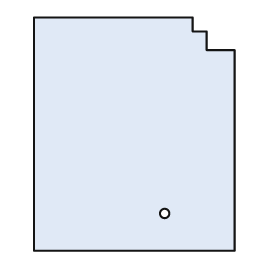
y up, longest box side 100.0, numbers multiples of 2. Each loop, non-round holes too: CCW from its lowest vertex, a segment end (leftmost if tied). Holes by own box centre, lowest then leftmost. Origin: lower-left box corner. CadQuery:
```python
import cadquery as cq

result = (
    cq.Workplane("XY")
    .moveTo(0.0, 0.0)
    .lineTo(86.0, 0.0)
    .lineTo(86.0, 86.0)
    .lineTo(74.0, 86.0)
    .lineTo(74.0, 94.0)
    .lineTo(68.0, 94.0)
    .lineTo(68.0, 100.0)
    .lineTo(0.0, 100.0)
    .close()
    .moveTo(56.0, 16.0)
    .circle(2.0)
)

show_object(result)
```